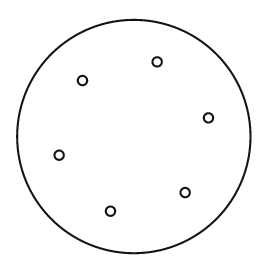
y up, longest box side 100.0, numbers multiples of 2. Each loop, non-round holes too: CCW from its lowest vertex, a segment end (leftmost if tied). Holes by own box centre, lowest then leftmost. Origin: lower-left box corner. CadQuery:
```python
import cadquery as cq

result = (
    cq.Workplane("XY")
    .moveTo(50.0, 50.0)
    .circle(50.0)
    .moveTo(40.0, 18.0)
    .circle(2.0)
    .moveTo(72.0, 26.0)
    .circle(2.0)
    .moveTo(18.0, 42.0)
    .circle(2.0)
    .moveTo(82.0, 58.0)
    .circle(2.0)
    .moveTo(28.0, 74.0)
    .circle(2.0)
    .moveTo(60.0, 82.0)
    .circle(2.0)
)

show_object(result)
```